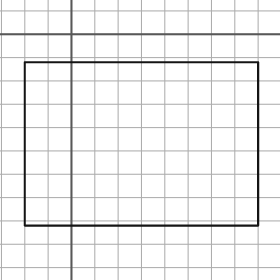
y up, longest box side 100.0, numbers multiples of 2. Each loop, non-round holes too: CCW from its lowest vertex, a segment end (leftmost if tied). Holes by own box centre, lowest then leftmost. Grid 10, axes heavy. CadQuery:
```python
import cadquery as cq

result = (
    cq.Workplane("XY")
    .moveTo(-20.0, -82.0)
    .lineTo(80.0, -82.0)
    .lineTo(80.0, -12.0)
    .lineTo(-20.0, -12.0)
    .close()
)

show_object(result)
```